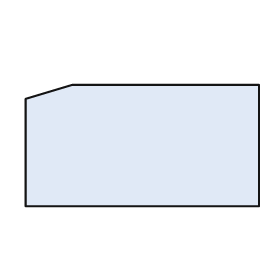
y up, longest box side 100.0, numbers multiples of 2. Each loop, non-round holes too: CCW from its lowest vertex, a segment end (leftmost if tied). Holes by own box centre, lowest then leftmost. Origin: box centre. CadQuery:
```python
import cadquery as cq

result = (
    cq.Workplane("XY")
    .moveTo(-50.0, -26.0)
    .lineTo(50.0, -26.0)
    .lineTo(50.0, 26.0)
    .lineTo(-30.0, 26.0)
    .lineTo(-50.0, 20.0)
    .close()
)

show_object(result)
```